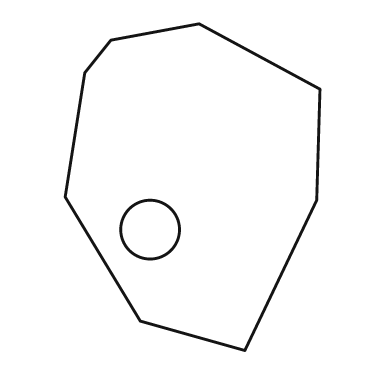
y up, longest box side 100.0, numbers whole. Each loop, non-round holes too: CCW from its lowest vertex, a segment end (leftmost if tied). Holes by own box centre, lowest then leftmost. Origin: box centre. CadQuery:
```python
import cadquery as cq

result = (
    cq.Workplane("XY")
    .moveTo(16.0, -50.0)
    .lineTo(38.0, -4.0)
    .lineTo(39.0, 30.0)
    .lineTo(2.0, 50.0)
    .lineTo(-25.0, 45.0)
    .lineTo(-33.0, 35.0)
    .lineTo(-39.0, -3.0)
    .lineTo(-16.0, -41.0)
    .close()
    .moveTo(-13.0, -13.0)
    .circle(9.0)
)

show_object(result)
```